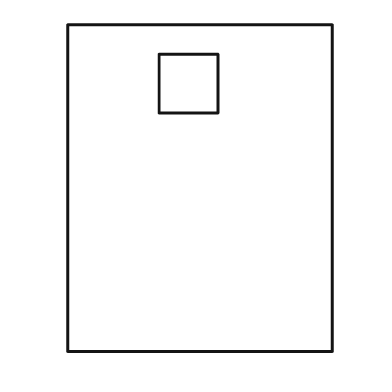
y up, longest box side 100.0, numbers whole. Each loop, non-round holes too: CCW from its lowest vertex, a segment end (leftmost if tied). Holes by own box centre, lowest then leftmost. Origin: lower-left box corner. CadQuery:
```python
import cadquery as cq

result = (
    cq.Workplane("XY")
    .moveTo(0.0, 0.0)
    .lineTo(81.0, 0.0)
    .lineTo(81.0, 100.0)
    .lineTo(0.0, 100.0)
    .close()
    .moveTo(28.0, 73.0)
    .lineTo(46.0, 73.0)
    .lineTo(46.0, 91.0)
    .lineTo(28.0, 91.0)
    .close()
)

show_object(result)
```